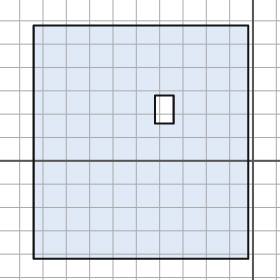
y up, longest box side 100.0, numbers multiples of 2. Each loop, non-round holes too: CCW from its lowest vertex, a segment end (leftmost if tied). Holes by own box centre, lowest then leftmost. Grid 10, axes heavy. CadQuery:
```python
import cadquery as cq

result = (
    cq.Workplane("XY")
    .moveTo(-94.0, -42.0)
    .lineTo(-2.0, -42.0)
    .lineTo(-2.0, 58.0)
    .lineTo(-94.0, 58.0)
    .close()
    .moveTo(-42.0, 16.0)
    .lineTo(-34.0, 16.0)
    .lineTo(-34.0, 28.0)
    .lineTo(-42.0, 28.0)
    .close()
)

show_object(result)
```